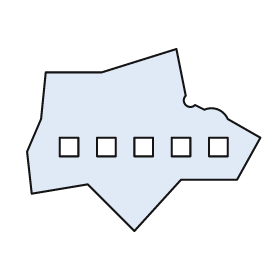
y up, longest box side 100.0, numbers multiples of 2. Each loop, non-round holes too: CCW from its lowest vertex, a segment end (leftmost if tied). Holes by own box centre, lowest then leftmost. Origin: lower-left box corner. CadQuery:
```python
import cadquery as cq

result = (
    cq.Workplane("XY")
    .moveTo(46.0, 0.0)
    .lineTo(66.0, 22.0)
    .lineTo(90.0, 22.0)
    .lineTo(100.0, 40.0)
    .lineTo(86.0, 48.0)
    .threePointArc((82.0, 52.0), (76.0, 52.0))
    .lineTo(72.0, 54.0)
    .threePointArc((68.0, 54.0), (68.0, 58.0))
    .lineTo(64.0, 78.0)
    .lineTo(32.0, 68.0)
    .lineTo(8.0, 68.0)
    .lineTo(6.0, 48.0)
    .lineTo(0.0, 34.0)
    .lineTo(2.0, 16.0)
    .lineTo(26.0, 20.0)
    .close()
    .moveTo(14.0, 32.0)
    .lineTo(22.0, 32.0)
    .lineTo(22.0, 40.0)
    .lineTo(14.0, 40.0)
    .close()
    .moveTo(30.0, 32.0)
    .lineTo(38.0, 32.0)
    .lineTo(38.0, 40.0)
    .lineTo(30.0, 40.0)
    .close()
    .moveTo(46.0, 32.0)
    .lineTo(54.0, 32.0)
    .lineTo(54.0, 40.0)
    .lineTo(46.0, 40.0)
    .close()
    .moveTo(62.0, 32.0)
    .lineTo(70.0, 32.0)
    .lineTo(70.0, 40.0)
    .lineTo(62.0, 40.0)
    .close()
    .moveTo(78.0, 32.0)
    .lineTo(86.0, 32.0)
    .lineTo(86.0, 40.0)
    .lineTo(78.0, 40.0)
    .close()
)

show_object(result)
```